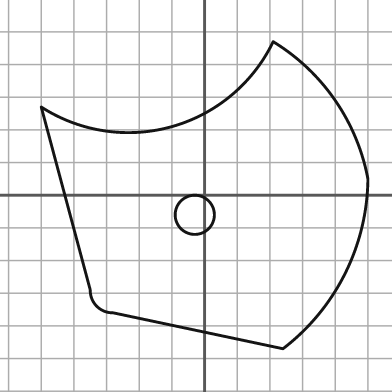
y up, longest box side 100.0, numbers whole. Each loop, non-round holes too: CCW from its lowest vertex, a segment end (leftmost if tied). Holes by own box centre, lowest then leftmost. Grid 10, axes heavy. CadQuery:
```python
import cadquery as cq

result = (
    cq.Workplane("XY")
    .moveTo(24.0, -47.0)
    .threePointArc((43.0, -24.0), (50.0, 5.0))
    .threePointArc((40.0, 29.0), (21.0, 47.0))
    .threePointArc((-10.0, 21.0), (-50.0, 27.0))
    .lineTo(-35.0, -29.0)
    .threePointArc((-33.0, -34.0), (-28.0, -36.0))
    .close()
    .moveTo(-3.0, -6.0)
    .circle(6.0)
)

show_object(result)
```